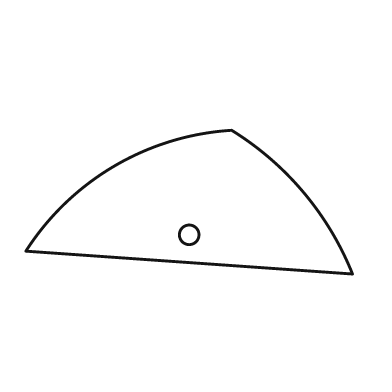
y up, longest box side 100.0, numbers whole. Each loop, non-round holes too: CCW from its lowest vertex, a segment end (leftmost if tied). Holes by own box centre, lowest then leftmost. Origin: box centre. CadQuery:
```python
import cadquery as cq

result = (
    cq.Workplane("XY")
    .moveTo(50.0, -22.0)
    .threePointArc((35.0, 3.0), (13.0, 22.0))
    .threePointArc((-23.0, 11.0), (-50.0, -15.0))
    .close()
    .moveTo(0.0, -10.0)
    .circle(3.0)
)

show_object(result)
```